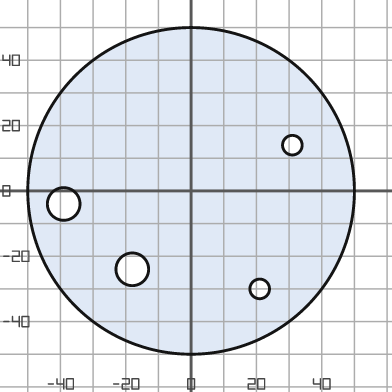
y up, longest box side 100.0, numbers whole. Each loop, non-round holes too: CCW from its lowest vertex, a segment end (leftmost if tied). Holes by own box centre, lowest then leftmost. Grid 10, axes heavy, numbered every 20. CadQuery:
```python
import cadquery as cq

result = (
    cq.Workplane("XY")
    .moveTo(0.0, 0.0)
    .circle(50.0)
    .moveTo(21.0, -30.0)
    .circle(3.0)
    .moveTo(-18.0, -24.0)
    .circle(5.0)
    .moveTo(-39.0, -4.0)
    .circle(5.0)
    .moveTo(31.0, 14.0)
    .circle(3.0)
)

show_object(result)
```